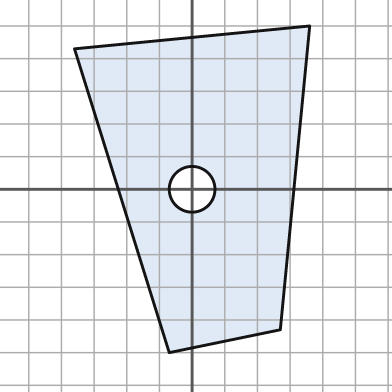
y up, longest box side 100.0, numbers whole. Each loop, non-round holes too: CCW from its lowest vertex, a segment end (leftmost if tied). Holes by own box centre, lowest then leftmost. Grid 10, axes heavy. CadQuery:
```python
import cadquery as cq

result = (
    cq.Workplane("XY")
    .moveTo(-7.0, -50.0)
    .lineTo(27.0, -43.0)
    .lineTo(36.0, 50.0)
    .lineTo(-36.0, 43.0)
    .close()
    .moveTo(0.0, 0.0)
    .circle(7.0)
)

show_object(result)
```